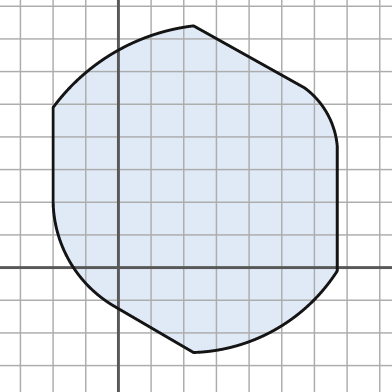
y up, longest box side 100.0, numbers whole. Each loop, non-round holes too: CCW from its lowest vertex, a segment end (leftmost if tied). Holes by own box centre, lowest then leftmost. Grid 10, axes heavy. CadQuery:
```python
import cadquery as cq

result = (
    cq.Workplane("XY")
    .moveTo(23.0, -26.0)
    .threePointArc((48.0, -19.0), (67.0, -1.0))
    .lineTo(67.0, 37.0)
    .threePointArc((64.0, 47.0), (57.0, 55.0))
    .lineTo(23.0, 74.0)
    .threePointArc((-1.0, 66.0), (-20.0, 49.0))
    .lineTo(-20.0, 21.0)
    .threePointArc((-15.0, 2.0), (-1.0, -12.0))
    .close()
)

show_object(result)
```